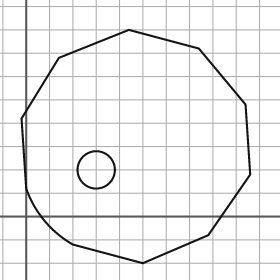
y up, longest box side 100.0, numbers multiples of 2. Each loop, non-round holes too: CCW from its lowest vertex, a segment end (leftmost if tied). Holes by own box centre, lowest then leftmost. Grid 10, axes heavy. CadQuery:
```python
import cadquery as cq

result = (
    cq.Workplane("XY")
    .moveTo(50.0, -20.0)
    .lineTo(78.0, -8.0)
    .lineTo(96.0, 18.0)
    .lineTo(94.0, 48.0)
    .lineTo(74.0, 72.0)
    .lineTo(44.0, 80.0)
    .lineTo(14.0, 68.0)
    .lineTo(-2.0, 42.0)
    .lineTo(0.0, 12.0)
    .threePointArc((8.0, -2.0), (20.0, -12.0))
    .close()
    .moveTo(30.0, 20.0)
    .circle(8.0)
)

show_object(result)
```